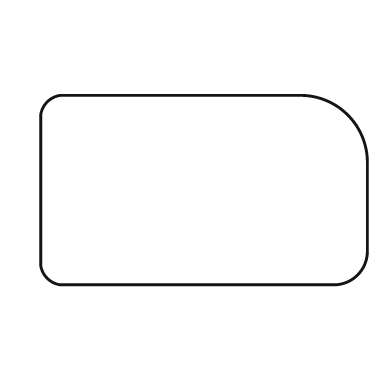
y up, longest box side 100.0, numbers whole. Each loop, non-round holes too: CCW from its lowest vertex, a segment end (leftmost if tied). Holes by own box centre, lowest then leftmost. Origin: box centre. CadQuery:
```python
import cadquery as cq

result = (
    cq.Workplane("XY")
    .moveTo(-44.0, -29.0)
    .lineTo(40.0, -29.0)
    .threePointArc((47.0, -26.0), (50.0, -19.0))
    .lineTo(50.0, 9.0)
    .threePointArc((44.0, 23.0), (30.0, 29.0))
    .lineTo(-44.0, 29.0)
    .threePointArc((-48.0, 27.0), (-50.0, 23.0))
    .lineTo(-50.0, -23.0)
    .threePointArc((-48.0, -27.0), (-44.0, -29.0))
    .close()
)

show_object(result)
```